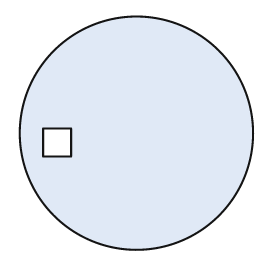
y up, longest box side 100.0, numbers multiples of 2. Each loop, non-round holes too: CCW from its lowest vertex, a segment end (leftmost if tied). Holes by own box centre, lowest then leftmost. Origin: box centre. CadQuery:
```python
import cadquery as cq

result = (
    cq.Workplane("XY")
    .moveTo(0.0, 0.0)
    .circle(50.0)
    .moveTo(-40.0, -10.0)
    .lineTo(-28.0, -10.0)
    .lineTo(-28.0, 2.0)
    .lineTo(-40.0, 2.0)
    .close()
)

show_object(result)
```